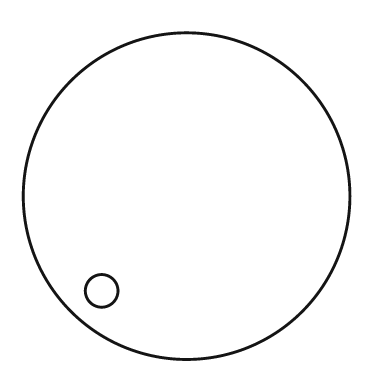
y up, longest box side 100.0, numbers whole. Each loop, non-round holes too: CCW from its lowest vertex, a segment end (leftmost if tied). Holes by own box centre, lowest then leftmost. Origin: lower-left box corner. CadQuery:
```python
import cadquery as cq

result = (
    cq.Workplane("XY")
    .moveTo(50.0, 50.0)
    .circle(50.0)
    .moveTo(24.0, 21.0)
    .circle(5.0)
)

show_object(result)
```